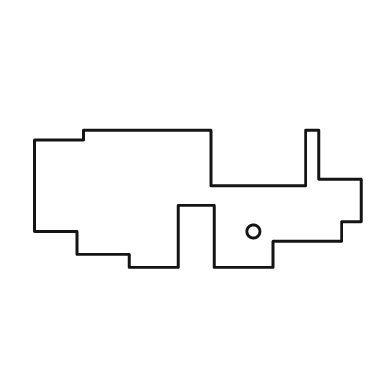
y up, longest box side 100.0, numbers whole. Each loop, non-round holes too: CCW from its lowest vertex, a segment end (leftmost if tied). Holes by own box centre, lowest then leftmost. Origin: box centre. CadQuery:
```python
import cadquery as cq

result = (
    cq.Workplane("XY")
    .moveTo(-21.0, -21.0)
    .lineTo(-6.0, -21.0)
    .lineTo(-6.0, -2.0)
    .lineTo(5.0, -2.0)
    .lineTo(5.0, -21.0)
    .lineTo(23.0, -21.0)
    .lineTo(23.0, -13.0)
    .lineTo(44.0, -13.0)
    .lineTo(44.0, -7.0)
    .lineTo(50.0, -7.0)
    .lineTo(50.0, 6.0)
    .lineTo(37.0, 6.0)
    .lineTo(37.0, 21.0)
    .lineTo(33.0, 21.0)
    .lineTo(33.0, 4.0)
    .lineTo(4.0, 4.0)
    .lineTo(4.0, 21.0)
    .lineTo(-35.0, 21.0)
    .lineTo(-35.0, 18.0)
    .lineTo(-50.0, 18.0)
    .lineTo(-50.0, -10.0)
    .lineTo(-37.0, -10.0)
    .lineTo(-37.0, -17.0)
    .lineTo(-21.0, -17.0)
    .close()
    .moveTo(17.0, -10.0)
    .circle(2.0)
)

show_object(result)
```